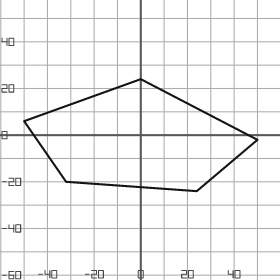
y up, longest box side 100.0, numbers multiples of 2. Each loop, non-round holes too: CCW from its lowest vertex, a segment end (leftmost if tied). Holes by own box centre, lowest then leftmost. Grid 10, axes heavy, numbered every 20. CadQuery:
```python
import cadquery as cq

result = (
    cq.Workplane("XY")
    .moveTo(24.0, -24.0)
    .lineTo(50.0, -2.0)
    .lineTo(0.0, 24.0)
    .lineTo(-50.0, 6.0)
    .lineTo(-32.0, -20.0)
    .close()
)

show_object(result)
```